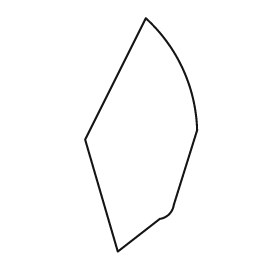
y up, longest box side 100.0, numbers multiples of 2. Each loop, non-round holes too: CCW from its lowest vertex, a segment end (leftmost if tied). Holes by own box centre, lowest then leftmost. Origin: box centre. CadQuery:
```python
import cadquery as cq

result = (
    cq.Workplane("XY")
    .moveTo(-10.0, -50.0)
    .lineTo(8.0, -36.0)
    .threePointArc((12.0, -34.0), (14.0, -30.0))
    .lineTo(24.0, 2.0)
    .threePointArc((18.0, 28.0), (2.0, 50.0))
    .lineTo(-24.0, -2.0)
    .close()
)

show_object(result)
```